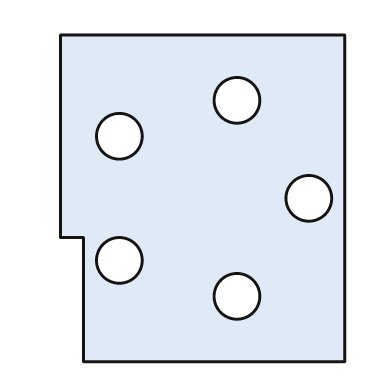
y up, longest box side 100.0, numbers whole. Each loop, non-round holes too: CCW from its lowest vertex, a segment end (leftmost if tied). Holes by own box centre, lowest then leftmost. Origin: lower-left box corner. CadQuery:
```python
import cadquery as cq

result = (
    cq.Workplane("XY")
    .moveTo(7.0, 0.0)
    .lineTo(87.0, 0.0)
    .lineTo(87.0, 100.0)
    .lineTo(0.0, 100.0)
    .lineTo(0.0, 38.0)
    .lineTo(7.0, 38.0)
    .close()
    .moveTo(54.0, 20.0)
    .circle(7.0)
    .moveTo(18.0, 31.0)
    .circle(7.0)
    .moveTo(76.0, 50.0)
    .circle(7.0)
    .moveTo(18.0, 69.0)
    .circle(7.0)
    .moveTo(54.0, 80.0)
    .circle(7.0)
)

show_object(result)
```